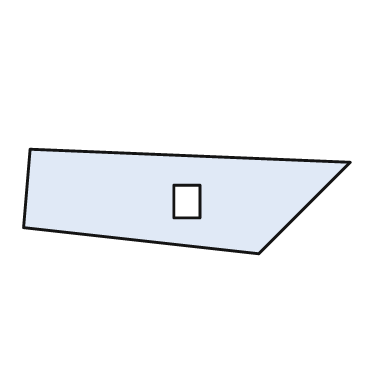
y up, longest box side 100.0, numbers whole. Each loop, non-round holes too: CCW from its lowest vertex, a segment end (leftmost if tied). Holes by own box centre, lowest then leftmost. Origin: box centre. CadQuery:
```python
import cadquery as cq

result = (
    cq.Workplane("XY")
    .moveTo(22.0, -16.0)
    .lineTo(50.0, 12.0)
    .lineTo(-48.0, 16.0)
    .lineTo(-50.0, -8.0)
    .close()
    .moveTo(-4.0, -5.0)
    .lineTo(4.0, -5.0)
    .lineTo(4.0, 5.0)
    .lineTo(-4.0, 5.0)
    .close()
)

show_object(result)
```